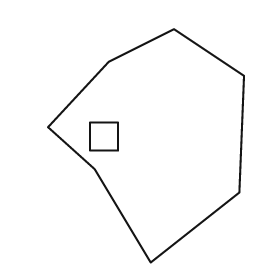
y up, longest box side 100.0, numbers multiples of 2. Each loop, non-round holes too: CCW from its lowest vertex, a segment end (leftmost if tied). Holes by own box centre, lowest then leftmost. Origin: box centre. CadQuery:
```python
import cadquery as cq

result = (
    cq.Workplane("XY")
    .moveTo(2.0, -50.0)
    .lineTo(40.0, -20.0)
    .lineTo(42.0, 30.0)
    .lineTo(12.0, 50.0)
    .lineTo(-16.0, 36.0)
    .lineTo(-42.0, 8.0)
    .lineTo(-22.0, -10.0)
    .close()
    .moveTo(-24.0, -2.0)
    .lineTo(-12.0, -2.0)
    .lineTo(-12.0, 10.0)
    .lineTo(-24.0, 10.0)
    .close()
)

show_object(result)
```